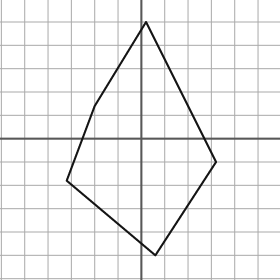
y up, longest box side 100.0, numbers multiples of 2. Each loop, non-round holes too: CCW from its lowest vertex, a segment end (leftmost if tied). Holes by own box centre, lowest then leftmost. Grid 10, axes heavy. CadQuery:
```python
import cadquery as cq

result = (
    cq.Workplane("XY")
    .moveTo(6.0, -50.0)
    .lineTo(32.0, -10.0)
    .lineTo(2.0, 50.0)
    .lineTo(-20.0, 14.0)
    .lineTo(-32.0, -18.0)
    .close()
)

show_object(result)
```